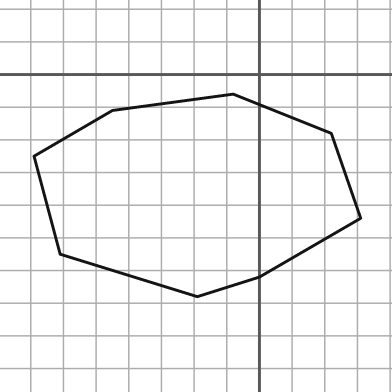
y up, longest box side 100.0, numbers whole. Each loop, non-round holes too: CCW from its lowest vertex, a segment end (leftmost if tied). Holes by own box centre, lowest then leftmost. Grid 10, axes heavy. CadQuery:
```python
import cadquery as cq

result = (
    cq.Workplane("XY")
    .moveTo(-19.0, -68.0)
    .lineTo(0.0, -62.0)
    .lineTo(31.0, -44.0)
    .lineTo(22.0, -18.0)
    .lineTo(-8.0, -6.0)
    .lineTo(-45.0, -11.0)
    .lineTo(-69.0, -25.0)
    .lineTo(-61.0, -55.0)
    .close()
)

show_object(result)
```